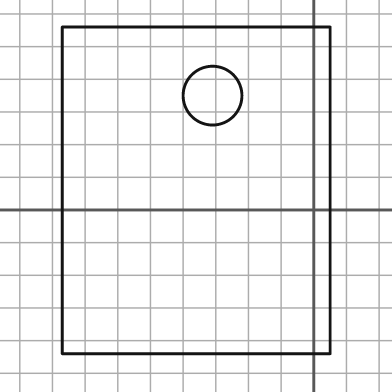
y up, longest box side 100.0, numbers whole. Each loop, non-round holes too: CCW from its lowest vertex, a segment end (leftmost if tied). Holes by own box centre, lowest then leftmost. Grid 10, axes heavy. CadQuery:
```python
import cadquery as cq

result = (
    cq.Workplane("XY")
    .moveTo(-77.0, -44.0)
    .lineTo(5.0, -44.0)
    .lineTo(5.0, 56.0)
    .lineTo(-77.0, 56.0)
    .close()
    .moveTo(-31.0, 35.0)
    .circle(9.0)
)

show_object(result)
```